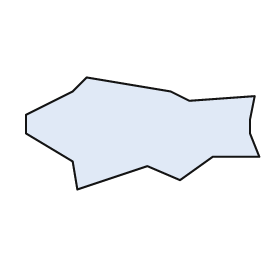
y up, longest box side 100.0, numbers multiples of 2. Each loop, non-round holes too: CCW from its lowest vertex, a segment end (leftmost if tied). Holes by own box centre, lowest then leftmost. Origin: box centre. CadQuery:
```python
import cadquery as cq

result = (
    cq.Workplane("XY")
    .moveTo(-28.0, -24.0)
    .lineTo(2.0, -14.0)
    .lineTo(16.0, -20.0)
    .lineTo(30.0, -10.0)
    .lineTo(50.0, -10.0)
    .lineTo(46.0, 0.0)
    .lineTo(46.0, 6.0)
    .lineTo(48.0, 16.0)
    .lineTo(20.0, 14.0)
    .lineTo(12.0, 18.0)
    .lineTo(-24.0, 24.0)
    .lineTo(-30.0, 18.0)
    .lineTo(-50.0, 8.0)
    .lineTo(-50.0, 0.0)
    .lineTo(-30.0, -12.0)
    .close()
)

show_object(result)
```